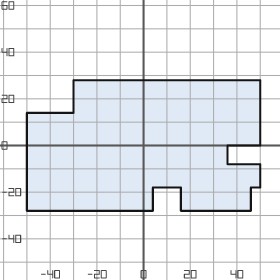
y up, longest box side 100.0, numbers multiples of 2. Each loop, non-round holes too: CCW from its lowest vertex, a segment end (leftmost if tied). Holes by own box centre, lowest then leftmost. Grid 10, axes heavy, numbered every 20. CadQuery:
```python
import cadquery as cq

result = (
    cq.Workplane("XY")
    .moveTo(-50.0, -28.0)
    .lineTo(4.0, -28.0)
    .lineTo(4.0, -18.0)
    .lineTo(16.0, -18.0)
    .lineTo(16.0, -28.0)
    .lineTo(46.0, -28.0)
    .lineTo(46.0, -18.0)
    .lineTo(50.0, -18.0)
    .lineTo(50.0, -8.0)
    .lineTo(36.0, -8.0)
    .lineTo(36.0, 0.0)
    .lineTo(50.0, 0.0)
    .lineTo(50.0, 28.0)
    .lineTo(-30.0, 28.0)
    .lineTo(-30.0, 14.0)
    .lineTo(-50.0, 14.0)
    .close()
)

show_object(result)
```